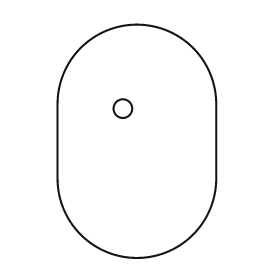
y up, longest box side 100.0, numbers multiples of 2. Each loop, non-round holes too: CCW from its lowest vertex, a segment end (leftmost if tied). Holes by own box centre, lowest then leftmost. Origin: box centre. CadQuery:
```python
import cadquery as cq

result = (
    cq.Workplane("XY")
    .moveTo(-34.0, -16.0)
    .threePointArc((0.0, -50.0), (34.0, -16.0))
    .lineTo(34.0, 16.0)
    .threePointArc((0.0, 50.0), (-34.0, 16.0))
    .close()
    .moveTo(-6.0, 14.0)
    .circle(4.0)
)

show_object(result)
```